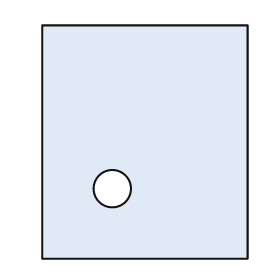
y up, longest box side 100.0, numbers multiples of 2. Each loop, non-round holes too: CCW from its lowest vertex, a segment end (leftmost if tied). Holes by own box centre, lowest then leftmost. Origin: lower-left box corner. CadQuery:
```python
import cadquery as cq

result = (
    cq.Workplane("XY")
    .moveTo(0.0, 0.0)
    .lineTo(88.0, 0.0)
    .lineTo(88.0, 100.0)
    .lineTo(0.0, 100.0)
    .close()
    .moveTo(30.0, 30.0)
    .circle(8.0)
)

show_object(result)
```